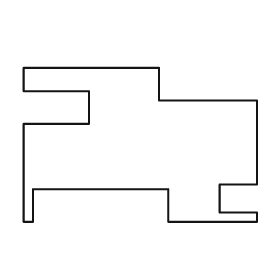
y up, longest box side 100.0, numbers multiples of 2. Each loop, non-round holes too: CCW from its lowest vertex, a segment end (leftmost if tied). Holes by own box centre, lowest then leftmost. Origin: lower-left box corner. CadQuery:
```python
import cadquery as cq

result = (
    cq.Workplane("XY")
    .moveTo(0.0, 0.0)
    .lineTo(4.0, 0.0)
    .lineTo(4.0, 14.0)
    .lineTo(62.0, 14.0)
    .lineTo(62.0, 0.0)
    .lineTo(100.0, 0.0)
    .lineTo(100.0, 4.0)
    .lineTo(84.0, 4.0)
    .lineTo(84.0, 16.0)
    .lineTo(100.0, 16.0)
    .lineTo(100.0, 52.0)
    .lineTo(58.0, 52.0)
    .lineTo(58.0, 66.0)
    .lineTo(0.0, 66.0)
    .lineTo(0.0, 56.0)
    .lineTo(28.0, 56.0)
    .lineTo(28.0, 42.0)
    .lineTo(0.0, 42.0)
    .close()
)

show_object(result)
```